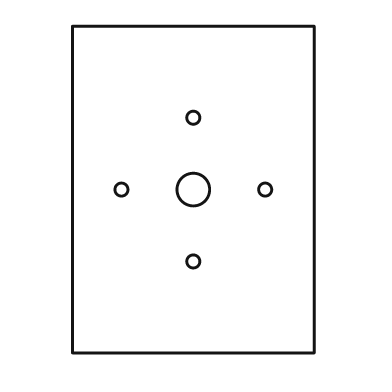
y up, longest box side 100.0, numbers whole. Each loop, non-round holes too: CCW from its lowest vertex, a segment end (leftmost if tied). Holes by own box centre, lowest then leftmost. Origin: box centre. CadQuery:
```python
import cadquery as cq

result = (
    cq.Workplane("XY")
    .moveTo(-37.0, -50.0)
    .lineTo(37.0, -50.0)
    .lineTo(37.0, 50.0)
    .lineTo(-37.0, 50.0)
    .close()
    .moveTo(0.0, -22.0)
    .circle(2.0)
    .moveTo(-22.0, 0.0)
    .circle(2.0)
    .moveTo(0.0, 0.0)
    .circle(5.0)
    .moveTo(22.0, 0.0)
    .circle(2.0)
    .moveTo(0.0, 22.0)
    .circle(2.0)
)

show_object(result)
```